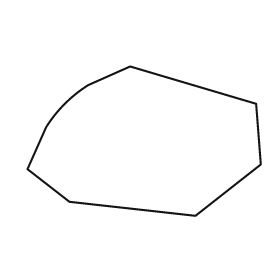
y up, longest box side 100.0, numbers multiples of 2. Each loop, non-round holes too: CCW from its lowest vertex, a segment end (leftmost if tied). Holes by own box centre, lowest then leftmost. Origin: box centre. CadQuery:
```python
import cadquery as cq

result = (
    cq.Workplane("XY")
    .moveTo(22.0, -32.0)
    .lineTo(50.0, -10.0)
    .lineTo(48.0, 16.0)
    .lineTo(-6.0, 32.0)
    .lineTo(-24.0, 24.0)
    .threePointArc((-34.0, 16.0), (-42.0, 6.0))
    .lineTo(-50.0, -12.0)
    .lineTo(-32.0, -26.0)
    .close()
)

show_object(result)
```